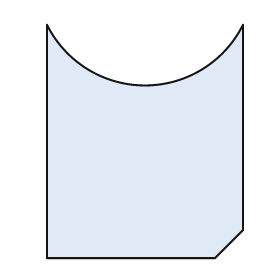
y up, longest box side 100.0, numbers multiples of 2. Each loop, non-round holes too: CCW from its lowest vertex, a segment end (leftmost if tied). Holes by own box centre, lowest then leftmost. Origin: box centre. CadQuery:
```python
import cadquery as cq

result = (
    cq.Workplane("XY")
    .moveTo(-42.0, -50.0)
    .lineTo(30.0, -50.0)
    .lineTo(42.0, -38.0)
    .lineTo(42.0, 50.0)
    .threePointArc((0.0, 24.0), (-42.0, 50.0))
    .close()
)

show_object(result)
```